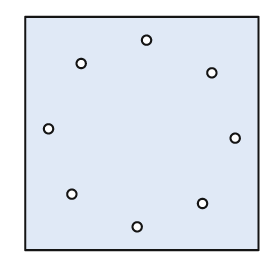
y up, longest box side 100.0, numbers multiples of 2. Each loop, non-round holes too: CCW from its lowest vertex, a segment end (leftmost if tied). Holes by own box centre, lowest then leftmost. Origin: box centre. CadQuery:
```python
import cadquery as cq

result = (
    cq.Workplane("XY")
    .moveTo(-50.0, -50.0)
    .lineTo(50.0, -50.0)
    .lineTo(50.0, 50.0)
    .lineTo(-50.0, 50.0)
    .close()
    .moveTo(-2.0, -40.0)
    .circle(2.0)
    .moveTo(26.0, -30.0)
    .circle(2.0)
    .moveTo(-30.0, -26.0)
    .circle(2.0)
    .moveTo(40.0, -2.0)
    .circle(2.0)
    .moveTo(-40.0, 2.0)
    .circle(2.0)
    .moveTo(30.0, 26.0)
    .circle(2.0)
    .moveTo(-26.0, 30.0)
    .circle(2.0)
    .moveTo(2.0, 40.0)
    .circle(2.0)
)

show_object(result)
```